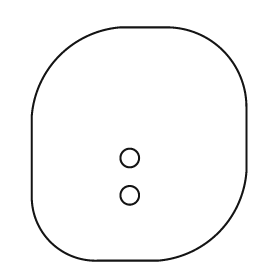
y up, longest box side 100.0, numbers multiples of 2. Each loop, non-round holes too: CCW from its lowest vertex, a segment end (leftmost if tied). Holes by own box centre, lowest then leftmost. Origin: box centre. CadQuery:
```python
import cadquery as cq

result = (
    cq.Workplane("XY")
    .moveTo(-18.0, -50.0)
    .lineTo(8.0, -50.0)
    .threePointArc((34.0, -38.0), (46.0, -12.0))
    .lineTo(46.0, 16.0)
    .threePointArc((36.0, 40.0), (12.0, 50.0))
    .lineTo(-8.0, 50.0)
    .threePointArc((-34.0, 38.0), (-46.0, 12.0))
    .lineTo(-46.0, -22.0)
    .threePointArc((-38.0, -42.0), (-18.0, -50.0))
    .close()
    .moveTo(-4.0, -22.0)
    .circle(4.0)
    .moveTo(-4.0, -6.0)
    .circle(4.0)
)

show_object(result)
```